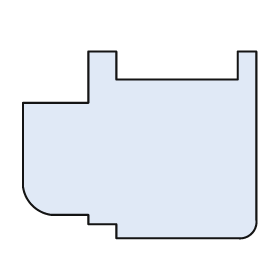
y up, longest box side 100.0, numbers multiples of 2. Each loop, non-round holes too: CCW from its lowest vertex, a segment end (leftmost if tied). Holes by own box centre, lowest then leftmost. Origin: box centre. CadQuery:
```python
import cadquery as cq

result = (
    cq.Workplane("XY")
    .moveTo(-10.0, -40.0)
    .lineTo(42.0, -40.0)
    .threePointArc((48.0, -38.0), (50.0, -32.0))
    .lineTo(50.0, 40.0)
    .lineTo(42.0, 40.0)
    .lineTo(42.0, 28.0)
    .lineTo(-10.0, 28.0)
    .lineTo(-10.0, 40.0)
    .lineTo(-22.0, 40.0)
    .lineTo(-22.0, 18.0)
    .lineTo(-50.0, 18.0)
    .lineTo(-50.0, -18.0)
    .threePointArc((-46.0, -26.0), (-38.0, -30.0))
    .lineTo(-22.0, -30.0)
    .lineTo(-22.0, -34.0)
    .lineTo(-10.0, -34.0)
    .close()
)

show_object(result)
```